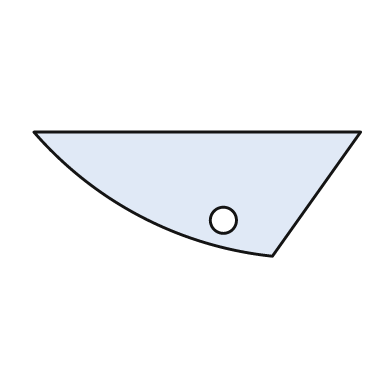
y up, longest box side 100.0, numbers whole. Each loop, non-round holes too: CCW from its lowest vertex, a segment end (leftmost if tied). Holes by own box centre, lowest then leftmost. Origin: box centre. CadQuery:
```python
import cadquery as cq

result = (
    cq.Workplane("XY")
    .moveTo(23.0, -19.0)
    .lineTo(50.0, 19.0)
    .lineTo(-50.0, 19.0)
    .threePointArc((-17.0, -7.0), (23.0, -19.0))
    .close()
    .moveTo(8.0, -8.0)
    .circle(4.0)
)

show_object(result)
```